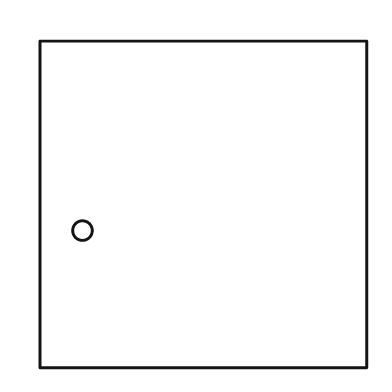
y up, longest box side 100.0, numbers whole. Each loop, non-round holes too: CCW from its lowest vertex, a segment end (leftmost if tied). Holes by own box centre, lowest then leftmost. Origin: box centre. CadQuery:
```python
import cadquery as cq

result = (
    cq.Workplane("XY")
    .moveTo(-50.0, -50.0)
    .lineTo(50.0, -50.0)
    .lineTo(50.0, 50.0)
    .lineTo(-50.0, 50.0)
    .close()
    .moveTo(-37.0, -8.0)
    .circle(3.0)
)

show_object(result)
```